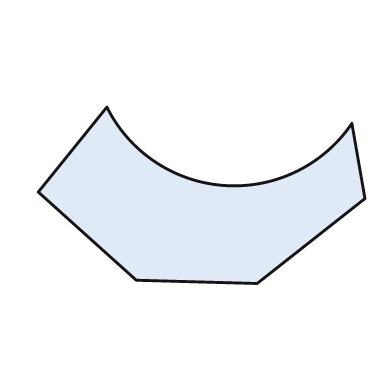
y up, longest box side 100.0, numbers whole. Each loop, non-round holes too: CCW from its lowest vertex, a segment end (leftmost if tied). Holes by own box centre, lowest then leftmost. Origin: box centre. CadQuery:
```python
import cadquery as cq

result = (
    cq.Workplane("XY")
    .moveTo(17.0, -27.0)
    .lineTo(50.0, -1.0)
    .lineTo(46.0, 22.0)
    .threePointArc((7.0, 3.0), (-29.0, 27.0))
    .lineTo(-50.0, 1.0)
    .lineTo(-20.0, -26.0)
    .close()
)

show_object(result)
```